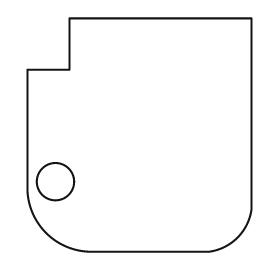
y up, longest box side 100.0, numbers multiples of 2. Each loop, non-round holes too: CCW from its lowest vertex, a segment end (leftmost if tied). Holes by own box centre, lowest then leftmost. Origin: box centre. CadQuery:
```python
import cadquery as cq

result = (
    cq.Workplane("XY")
    .moveTo(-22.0, -50.0)
    .lineTo(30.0, -50.0)
    .threePointArc((42.0, -44.0), (48.0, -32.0))
    .lineTo(48.0, 50.0)
    .lineTo(-30.0, 50.0)
    .lineTo(-30.0, 28.0)
    .lineTo(-48.0, 28.0)
    .lineTo(-48.0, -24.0)
    .threePointArc((-40.0, -42.0), (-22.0, -50.0))
    .close()
    .moveTo(-36.0, -20.0)
    .circle(8.0)
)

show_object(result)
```